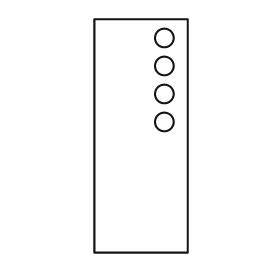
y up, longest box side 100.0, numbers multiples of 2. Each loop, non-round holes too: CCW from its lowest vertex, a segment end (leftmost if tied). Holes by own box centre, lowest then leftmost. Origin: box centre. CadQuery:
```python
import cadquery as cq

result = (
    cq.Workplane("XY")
    .moveTo(-20.0, -50.0)
    .lineTo(20.0, -50.0)
    .lineTo(20.0, 50.0)
    .lineTo(-20.0, 50.0)
    .close()
    .moveTo(10.0, 6.0)
    .circle(4.0)
    .moveTo(10.0, 18.0)
    .circle(4.0)
    .moveTo(10.0, 30.0)
    .circle(4.0)
    .moveTo(10.0, 42.0)
    .circle(4.0)
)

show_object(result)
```